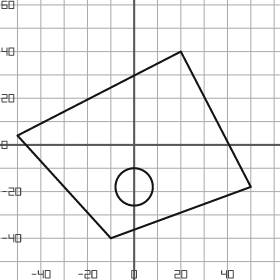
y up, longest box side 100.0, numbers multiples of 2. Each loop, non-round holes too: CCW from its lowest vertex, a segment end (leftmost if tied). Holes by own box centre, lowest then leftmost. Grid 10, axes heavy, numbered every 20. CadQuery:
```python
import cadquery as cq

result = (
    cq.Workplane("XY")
    .moveTo(-10.0, -40.0)
    .lineTo(50.0, -18.0)
    .lineTo(20.0, 40.0)
    .lineTo(-50.0, 4.0)
    .close()
    .moveTo(0.0, -18.0)
    .circle(8.0)
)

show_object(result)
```